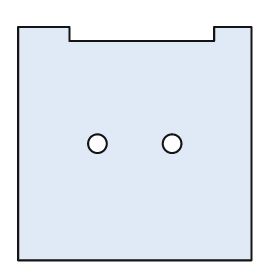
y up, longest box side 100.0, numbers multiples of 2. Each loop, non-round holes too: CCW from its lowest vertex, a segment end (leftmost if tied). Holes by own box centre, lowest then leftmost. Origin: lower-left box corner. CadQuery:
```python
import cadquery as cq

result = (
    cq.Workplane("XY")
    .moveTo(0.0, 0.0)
    .lineTo(100.0, 0.0)
    .lineTo(100.0, 100.0)
    .lineTo(84.0, 100.0)
    .lineTo(84.0, 94.0)
    .lineTo(22.0, 94.0)
    .lineTo(22.0, 100.0)
    .lineTo(0.0, 100.0)
    .close()
    .moveTo(34.0, 50.0)
    .circle(4.0)
    .moveTo(66.0, 50.0)
    .circle(4.0)
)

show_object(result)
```